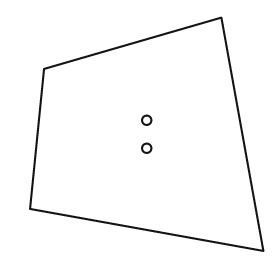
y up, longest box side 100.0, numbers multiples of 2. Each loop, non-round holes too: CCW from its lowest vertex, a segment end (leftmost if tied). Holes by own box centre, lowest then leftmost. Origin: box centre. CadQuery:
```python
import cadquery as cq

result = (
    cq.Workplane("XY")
    .moveTo(50.0, -50.0)
    .lineTo(32.0, 50.0)
    .lineTo(-44.0, 28.0)
    .lineTo(-50.0, -32.0)
    .close()
    .moveTo(0.0, -6.0)
    .circle(2.0)
    .moveTo(0.0, 6.0)
    .circle(2.0)
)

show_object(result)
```